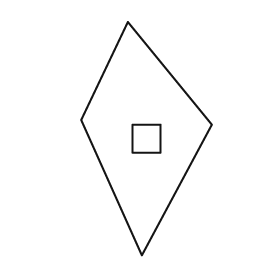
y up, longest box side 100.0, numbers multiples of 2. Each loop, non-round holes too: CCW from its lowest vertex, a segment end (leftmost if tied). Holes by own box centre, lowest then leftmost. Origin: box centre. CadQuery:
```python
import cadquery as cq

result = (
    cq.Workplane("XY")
    .moveTo(-2.0, -50.0)
    .lineTo(28.0, 6.0)
    .lineTo(-8.0, 50.0)
    .lineTo(-28.0, 8.0)
    .close()
    .moveTo(-6.0, -6.0)
    .lineTo(6.0, -6.0)
    .lineTo(6.0, 6.0)
    .lineTo(-6.0, 6.0)
    .close()
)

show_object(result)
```